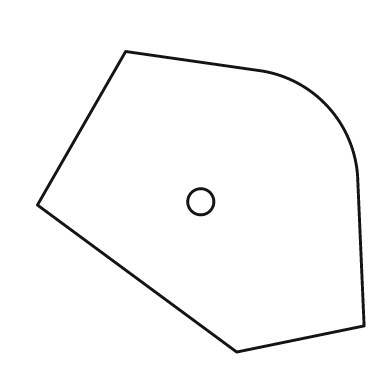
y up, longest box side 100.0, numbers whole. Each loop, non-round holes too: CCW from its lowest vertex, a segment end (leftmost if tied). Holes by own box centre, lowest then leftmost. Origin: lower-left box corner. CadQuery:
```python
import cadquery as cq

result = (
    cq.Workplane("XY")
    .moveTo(61.0, 0.0)
    .lineTo(100.0, 8.0)
    .lineTo(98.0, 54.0)
    .threePointArc((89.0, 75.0), (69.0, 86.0))
    .lineTo(27.0, 92.0)
    .lineTo(0.0, 45.0)
    .close()
    .moveTo(50.0, 46.0)
    .circle(4.0)
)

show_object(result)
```